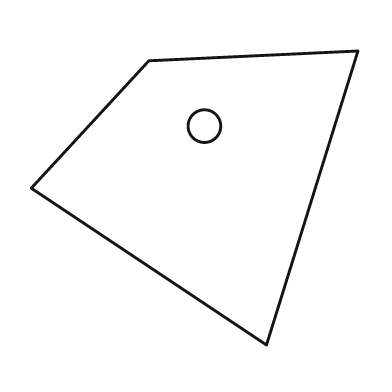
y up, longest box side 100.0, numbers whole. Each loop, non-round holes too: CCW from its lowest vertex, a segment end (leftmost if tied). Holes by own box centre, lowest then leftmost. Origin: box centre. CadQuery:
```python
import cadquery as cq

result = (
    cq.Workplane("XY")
    .moveTo(22.0, -45.0)
    .lineTo(50.0, 45.0)
    .lineTo(-14.0, 42.0)
    .lineTo(-50.0, 3.0)
    .close()
    .moveTo(3.0, 22.0)
    .circle(5.0)
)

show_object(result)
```